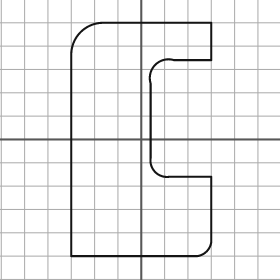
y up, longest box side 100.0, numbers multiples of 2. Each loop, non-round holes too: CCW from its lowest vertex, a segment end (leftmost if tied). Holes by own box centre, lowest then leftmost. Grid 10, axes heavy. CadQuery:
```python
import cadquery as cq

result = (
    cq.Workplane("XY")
    .moveTo(-30.0, -50.0)
    .lineTo(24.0, -50.0)
    .threePointArc((28.0, -48.0), (30.0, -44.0))
    .lineTo(30.0, -16.0)
    .lineTo(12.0, -16.0)
    .threePointArc((6.0, -14.0), (4.0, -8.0))
    .lineTo(4.0, 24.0)
    .threePointArc((6.0, 32.0), (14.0, 34.0))
    .lineTo(30.0, 34.0)
    .lineTo(30.0, 50.0)
    .lineTo(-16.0, 50.0)
    .threePointArc((-26.0, 46.0), (-30.0, 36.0))
    .close()
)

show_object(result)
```